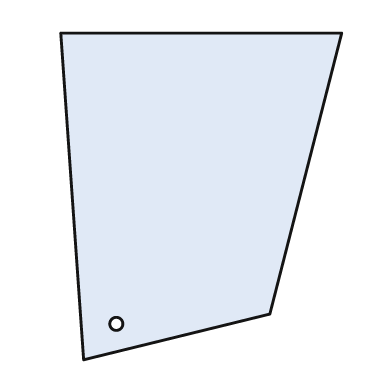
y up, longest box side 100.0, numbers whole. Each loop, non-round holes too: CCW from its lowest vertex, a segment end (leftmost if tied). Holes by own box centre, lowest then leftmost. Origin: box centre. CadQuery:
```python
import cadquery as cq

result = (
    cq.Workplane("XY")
    .moveTo(-36.0, -50.0)
    .lineTo(21.0, -36.0)
    .lineTo(43.0, 50.0)
    .lineTo(-43.0, 50.0)
    .close()
    .moveTo(-26.0, -39.0)
    .circle(2.0)
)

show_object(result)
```